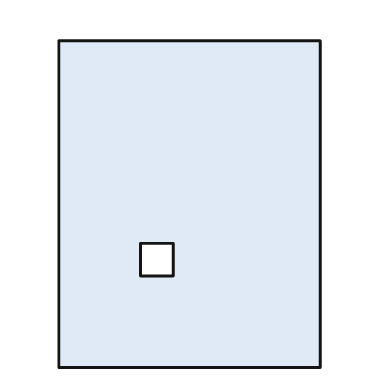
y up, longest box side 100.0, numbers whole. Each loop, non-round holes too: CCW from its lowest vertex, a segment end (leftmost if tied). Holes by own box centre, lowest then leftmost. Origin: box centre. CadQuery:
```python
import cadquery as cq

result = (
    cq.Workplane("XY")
    .moveTo(-40.0, -50.0)
    .lineTo(40.0, -50.0)
    .lineTo(40.0, 50.0)
    .lineTo(-40.0, 50.0)
    .close()
    .moveTo(-15.0, -22.0)
    .lineTo(-5.0, -22.0)
    .lineTo(-5.0, -12.0)
    .lineTo(-15.0, -12.0)
    .close()
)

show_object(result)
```